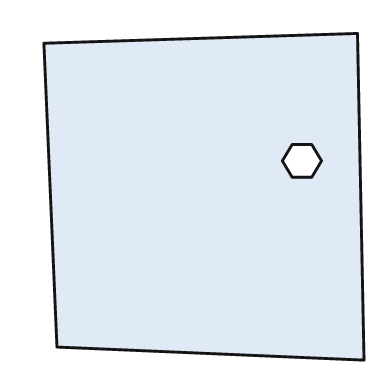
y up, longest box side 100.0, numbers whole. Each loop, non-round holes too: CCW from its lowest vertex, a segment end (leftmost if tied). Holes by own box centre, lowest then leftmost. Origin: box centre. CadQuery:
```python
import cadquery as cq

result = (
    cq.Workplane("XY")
    .moveTo(49.0, -50.0)
    .lineTo(47.0, 50.0)
    .lineTo(-49.0, 47.0)
    .lineTo(-45.0, -46.0)
    .close()
    .moveTo(27.0, 6.0)
    .lineTo(33.0, 6.0)
    .lineTo(36.0, 11.0)
    .lineTo(33.0, 16.0)
    .lineTo(27.0, 16.0)
    .lineTo(24.0, 11.0)
    .close()
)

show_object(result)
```